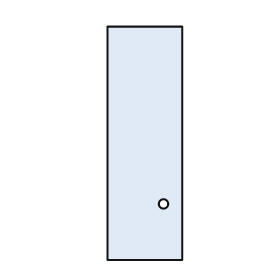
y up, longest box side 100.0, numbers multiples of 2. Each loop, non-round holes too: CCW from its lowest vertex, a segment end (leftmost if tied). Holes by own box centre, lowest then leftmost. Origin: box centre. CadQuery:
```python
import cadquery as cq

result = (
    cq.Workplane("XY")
    .moveTo(-16.0, -50.0)
    .lineTo(16.0, -50.0)
    .lineTo(16.0, 50.0)
    .lineTo(-16.0, 50.0)
    .close()
    .moveTo(8.0, -26.0)
    .circle(2.0)
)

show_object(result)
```